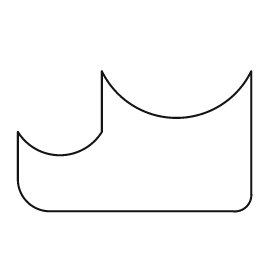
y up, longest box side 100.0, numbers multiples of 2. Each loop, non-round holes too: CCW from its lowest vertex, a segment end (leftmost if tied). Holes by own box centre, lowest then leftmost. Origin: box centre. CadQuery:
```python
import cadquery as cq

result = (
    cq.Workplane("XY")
    .moveTo(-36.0, -30.0)
    .lineTo(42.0, -30.0)
    .threePointArc((48.0, -28.0), (50.0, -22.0))
    .lineTo(50.0, 30.0)
    .threePointArc((18.0, 10.0), (-14.0, 30.0))
    .lineTo(-14.0, 4.0)
    .threePointArc((-32.0, -6.0), (-50.0, 4.0))
    .lineTo(-50.0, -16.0)
    .threePointArc((-46.0, -26.0), (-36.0, -30.0))
    .close()
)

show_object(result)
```